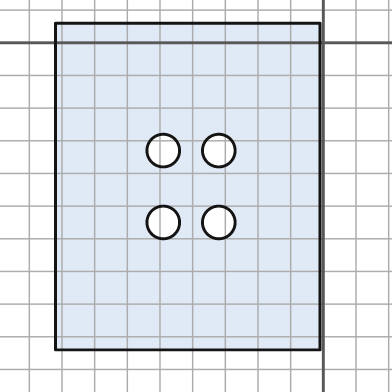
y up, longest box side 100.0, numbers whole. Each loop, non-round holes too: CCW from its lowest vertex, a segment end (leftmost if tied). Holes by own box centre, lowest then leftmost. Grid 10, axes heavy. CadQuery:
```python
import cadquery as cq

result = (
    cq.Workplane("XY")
    .moveTo(-82.0, -94.0)
    .lineTo(-1.0, -94.0)
    .lineTo(-1.0, 6.0)
    .lineTo(-82.0, 6.0)
    .close()
    .moveTo(-49.0, -55.0)
    .circle(5.0)
    .moveTo(-32.0, -55.0)
    .circle(5.0)
    .moveTo(-49.0, -33.0)
    .circle(5.0)
    .moveTo(-32.0, -33.0)
    .circle(5.0)
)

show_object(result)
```